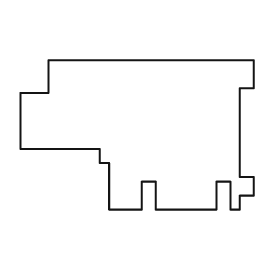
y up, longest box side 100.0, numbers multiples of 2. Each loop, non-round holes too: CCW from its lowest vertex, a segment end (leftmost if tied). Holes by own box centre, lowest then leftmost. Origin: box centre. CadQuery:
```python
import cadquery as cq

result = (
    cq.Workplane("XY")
    .moveTo(-12.0, -32.0)
    .lineTo(2.0, -32.0)
    .lineTo(2.0, -20.0)
    .lineTo(8.0, -20.0)
    .lineTo(8.0, -32.0)
    .lineTo(34.0, -32.0)
    .lineTo(34.0, -20.0)
    .lineTo(40.0, -20.0)
    .lineTo(40.0, -32.0)
    .lineTo(44.0, -32.0)
    .lineTo(44.0, -26.0)
    .lineTo(50.0, -26.0)
    .lineTo(50.0, -18.0)
    .lineTo(44.0, -18.0)
    .lineTo(44.0, 20.0)
    .lineTo(50.0, 20.0)
    .lineTo(50.0, 32.0)
    .lineTo(-38.0, 32.0)
    .lineTo(-38.0, 18.0)
    .lineTo(-50.0, 18.0)
    .lineTo(-50.0, -6.0)
    .lineTo(-16.0, -6.0)
    .lineTo(-16.0, -12.0)
    .lineTo(-12.0, -12.0)
    .close()
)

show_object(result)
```